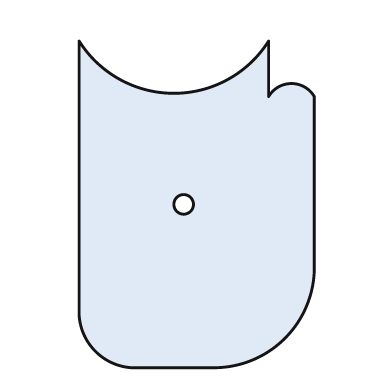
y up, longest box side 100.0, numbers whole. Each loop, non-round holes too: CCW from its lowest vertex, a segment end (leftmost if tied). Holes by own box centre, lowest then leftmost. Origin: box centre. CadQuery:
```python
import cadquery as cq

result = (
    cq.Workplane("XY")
    .moveTo(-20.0, -50.0)
    .lineTo(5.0, -50.0)
    .threePointArc((27.0, -41.0), (36.0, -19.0))
    .lineTo(36.0, 33.0)
    .threePointArc((29.0, 37.0), (22.0, 33.0))
    .lineTo(22.0, 50.0)
    .threePointArc((-7.0, 34.0), (-36.0, 50.0))
    .lineTo(-36.0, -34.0)
    .threePointArc((-31.0, -45.0), (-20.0, -50.0))
    .close()
    .moveTo(-4.0, 0.0)
    .circle(3.0)
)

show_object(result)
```